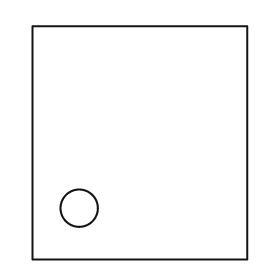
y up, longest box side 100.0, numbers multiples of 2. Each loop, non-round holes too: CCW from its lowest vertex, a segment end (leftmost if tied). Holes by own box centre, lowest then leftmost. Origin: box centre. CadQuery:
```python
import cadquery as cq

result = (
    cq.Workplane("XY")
    .moveTo(-46.0, -50.0)
    .lineTo(46.0, -50.0)
    .lineTo(46.0, 50.0)
    .lineTo(-46.0, 50.0)
    .close()
    .moveTo(-26.0, -28.0)
    .circle(8.0)
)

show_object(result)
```